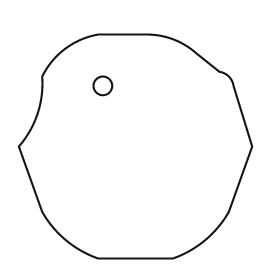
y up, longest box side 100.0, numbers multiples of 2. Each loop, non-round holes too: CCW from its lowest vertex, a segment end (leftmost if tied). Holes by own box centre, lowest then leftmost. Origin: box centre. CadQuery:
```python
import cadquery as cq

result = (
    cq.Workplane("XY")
    .moveTo(-16.0, -48.0)
    .lineTo(16.0, -48.0)
    .threePointArc((30.0, -40.0), (40.0, -28.0))
    .lineTo(50.0, 0.0)
    .lineTo(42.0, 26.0)
    .threePointArc((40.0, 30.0), (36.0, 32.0))
    .lineTo(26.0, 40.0)
    .threePointArc((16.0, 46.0), (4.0, 48.0))
    .lineTo(-16.0, 48.0)
    .threePointArc((-30.0, 42.0), (-40.0, 30.0))
    .threePointArc((-42.0, 14.0), (-50.0, 0.0))
    .lineTo(-40.0, -28.0)
    .threePointArc((-30.0, -40.0), (-16.0, -48.0))
    .close()
    .moveTo(-14.0, 26.0)
    .circle(4.0)
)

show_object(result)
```